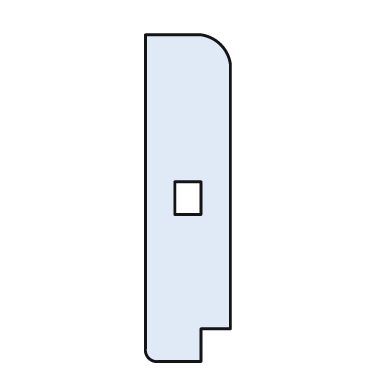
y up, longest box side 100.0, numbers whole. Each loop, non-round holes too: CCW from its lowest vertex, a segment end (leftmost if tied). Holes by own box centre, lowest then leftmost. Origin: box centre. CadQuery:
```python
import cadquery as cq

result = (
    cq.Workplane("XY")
    .moveTo(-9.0, -50.0)
    .lineTo(4.0, -50.0)
    .lineTo(4.0, -40.0)
    .lineTo(13.0, -40.0)
    .lineTo(13.0, 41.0)
    .threePointArc((10.0, 47.0), (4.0, 50.0))
    .lineTo(-13.0, 50.0)
    .lineTo(-13.0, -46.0)
    .threePointArc((-12.0, -49.0), (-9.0, -50.0))
    .close()
    .moveTo(-4.0, -5.0)
    .lineTo(4.0, -5.0)
    .lineTo(4.0, 5.0)
    .lineTo(-4.0, 5.0)
    .close()
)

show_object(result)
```